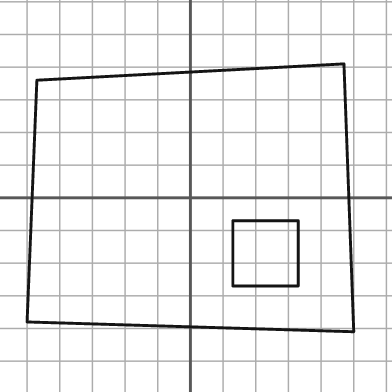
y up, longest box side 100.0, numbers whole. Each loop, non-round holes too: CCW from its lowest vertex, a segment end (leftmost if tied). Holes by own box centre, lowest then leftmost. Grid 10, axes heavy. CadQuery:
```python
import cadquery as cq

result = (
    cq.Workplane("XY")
    .moveTo(50.0, -41.0)
    .lineTo(47.0, 41.0)
    .lineTo(-47.0, 36.0)
    .lineTo(-50.0, -38.0)
    .close()
    .moveTo(13.0, -27.0)
    .lineTo(33.0, -27.0)
    .lineTo(33.0, -7.0)
    .lineTo(13.0, -7.0)
    .close()
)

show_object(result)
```